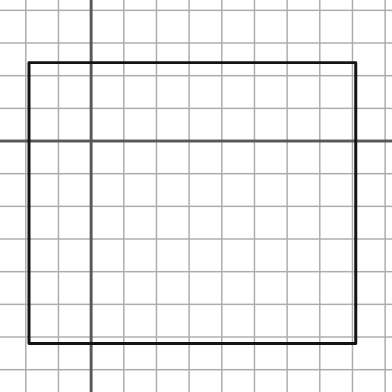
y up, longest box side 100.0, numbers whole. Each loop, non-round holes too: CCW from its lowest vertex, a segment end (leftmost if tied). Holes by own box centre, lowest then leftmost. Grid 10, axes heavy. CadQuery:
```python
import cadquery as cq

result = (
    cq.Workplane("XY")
    .moveTo(-19.0, -62.0)
    .lineTo(81.0, -62.0)
    .lineTo(81.0, 24.0)
    .lineTo(-19.0, 24.0)
    .close()
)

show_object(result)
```